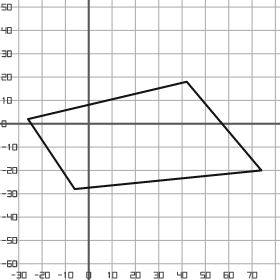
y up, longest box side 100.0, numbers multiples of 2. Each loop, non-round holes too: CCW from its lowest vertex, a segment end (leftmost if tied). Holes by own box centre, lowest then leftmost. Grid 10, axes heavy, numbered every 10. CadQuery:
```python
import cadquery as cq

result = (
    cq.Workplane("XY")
    .moveTo(-6.0, -28.0)
    .lineTo(74.0, -20.0)
    .lineTo(42.0, 18.0)
    .lineTo(-26.0, 2.0)
    .close()
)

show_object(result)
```